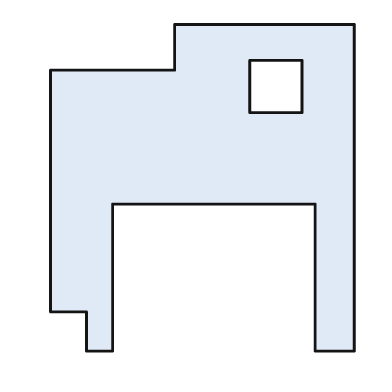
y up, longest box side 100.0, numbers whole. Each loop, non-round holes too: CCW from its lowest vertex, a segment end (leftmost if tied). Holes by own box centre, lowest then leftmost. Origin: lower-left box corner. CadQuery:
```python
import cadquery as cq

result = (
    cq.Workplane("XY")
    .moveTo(11.0, 0.0)
    .lineTo(19.0, 0.0)
    .lineTo(19.0, 45.0)
    .lineTo(81.0, 45.0)
    .lineTo(81.0, 0.0)
    .lineTo(93.0, 0.0)
    .lineTo(93.0, 100.0)
    .lineTo(38.0, 100.0)
    .lineTo(38.0, 86.0)
    .lineTo(0.0, 86.0)
    .lineTo(0.0, 12.0)
    .lineTo(11.0, 12.0)
    .close()
    .moveTo(61.0, 73.0)
    .lineTo(77.0, 73.0)
    .lineTo(77.0, 89.0)
    .lineTo(61.0, 89.0)
    .close()
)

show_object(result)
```